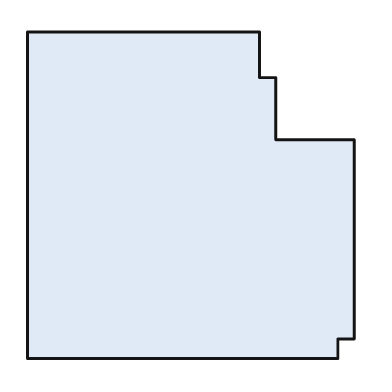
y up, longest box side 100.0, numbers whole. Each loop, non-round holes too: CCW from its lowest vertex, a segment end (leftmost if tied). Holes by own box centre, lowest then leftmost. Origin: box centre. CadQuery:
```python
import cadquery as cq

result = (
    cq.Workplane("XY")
    .moveTo(-50.0, -50.0)
    .lineTo(45.0, -50.0)
    .lineTo(45.0, -44.0)
    .lineTo(50.0, -44.0)
    .lineTo(50.0, 17.0)
    .lineTo(26.0, 17.0)
    .lineTo(26.0, 36.0)
    .lineTo(21.0, 36.0)
    .lineTo(21.0, 50.0)
    .lineTo(-50.0, 50.0)
    .close()
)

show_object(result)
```